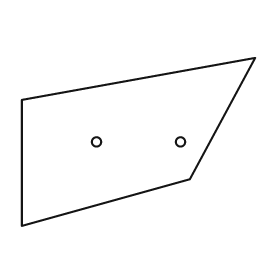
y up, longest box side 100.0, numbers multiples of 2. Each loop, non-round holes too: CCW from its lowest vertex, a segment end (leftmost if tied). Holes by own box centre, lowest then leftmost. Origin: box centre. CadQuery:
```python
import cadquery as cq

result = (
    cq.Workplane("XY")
    .moveTo(-50.0, -36.0)
    .lineTo(22.0, -16.0)
    .lineTo(50.0, 36.0)
    .lineTo(-50.0, 18.0)
    .close()
    .moveTo(-18.0, 0.0)
    .circle(2.0)
    .moveTo(18.0, 0.0)
    .circle(2.0)
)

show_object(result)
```